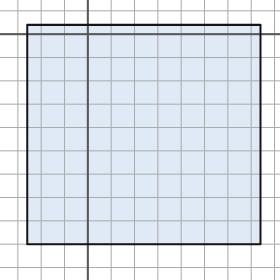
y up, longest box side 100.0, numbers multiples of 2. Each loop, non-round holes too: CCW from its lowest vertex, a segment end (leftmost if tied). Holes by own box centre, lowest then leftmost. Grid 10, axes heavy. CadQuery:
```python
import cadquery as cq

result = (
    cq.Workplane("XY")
    .moveTo(-26.0, -90.0)
    .lineTo(74.0, -90.0)
    .lineTo(74.0, 4.0)
    .lineTo(-26.0, 4.0)
    .close()
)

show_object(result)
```